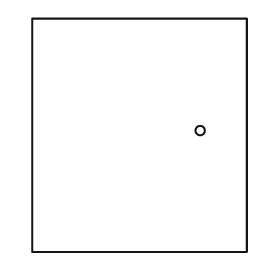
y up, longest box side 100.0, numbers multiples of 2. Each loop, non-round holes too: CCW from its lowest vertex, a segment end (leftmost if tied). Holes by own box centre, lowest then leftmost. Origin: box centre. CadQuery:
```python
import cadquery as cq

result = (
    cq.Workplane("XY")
    .moveTo(-46.0, -50.0)
    .lineTo(46.0, -50.0)
    .lineTo(46.0, 50.0)
    .lineTo(-46.0, 50.0)
    .close()
    .moveTo(26.0, 2.0)
    .circle(2.0)
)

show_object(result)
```